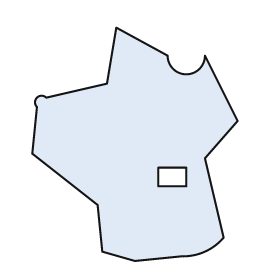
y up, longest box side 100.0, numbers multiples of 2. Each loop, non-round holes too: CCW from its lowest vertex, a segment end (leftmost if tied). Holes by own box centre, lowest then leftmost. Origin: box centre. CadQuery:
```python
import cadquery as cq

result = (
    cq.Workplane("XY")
    .moveTo(0.0, -50.0)
    .lineTo(20.0, -48.0)
    .threePointArc((30.0, -46.0), (38.0, -40.0))
    .lineTo(30.0, -6.0)
    .lineTo(44.0, 10.0)
    .lineTo(30.0, 38.0)
    .threePointArc((22.0, 30.0), (14.0, 38.0))
    .lineTo(-8.0, 50.0)
    .lineTo(-12.0, 26.0)
    .lineTo(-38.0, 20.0)
    .threePointArc((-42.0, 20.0), (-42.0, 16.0))
    .lineTo(-44.0, -4.0)
    .lineTo(-16.0, -26.0)
    .lineTo(-14.0, -46.0)
    .close()
    .moveTo(10.0, -18.0)
    .lineTo(22.0, -18.0)
    .lineTo(22.0, -10.0)
    .lineTo(10.0, -10.0)
    .close()
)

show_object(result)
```